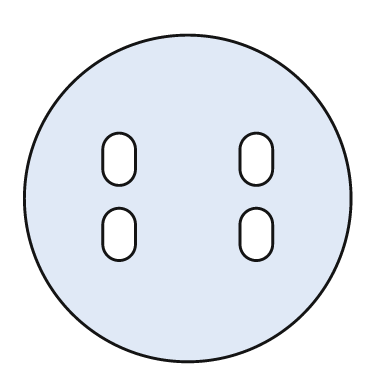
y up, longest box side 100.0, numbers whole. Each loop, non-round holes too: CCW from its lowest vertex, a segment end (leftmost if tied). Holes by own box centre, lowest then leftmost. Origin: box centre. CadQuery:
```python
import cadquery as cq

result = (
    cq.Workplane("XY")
    .moveTo(0.0, 0.0)
    .circle(50.0)
    .moveTo(-26.0, -14.0)
    .threePointArc((-21.0, -19.0), (-16.0, -14.0))
    .lineTo(-16.0, -8.0)
    .threePointArc((-21.0, -3.0), (-26.0, -8.0))
    .close()
    .moveTo(16.0, -14.0)
    .threePointArc((21.0, -19.0), (26.0, -14.0))
    .lineTo(26.0, -8.0)
    .threePointArc((21.0, -3.0), (16.0, -8.0))
    .close()
    .moveTo(-26.0, 9.0)
    .threePointArc((-21.0, 4.0), (-16.0, 9.0))
    .lineTo(-16.0, 15.0)
    .threePointArc((-21.0, 20.0), (-26.0, 15.0))
    .close()
    .moveTo(16.0, 9.0)
    .threePointArc((21.0, 4.0), (26.0, 9.0))
    .lineTo(26.0, 15.0)
    .threePointArc((21.0, 20.0), (16.0, 15.0))
    .close()
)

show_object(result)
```